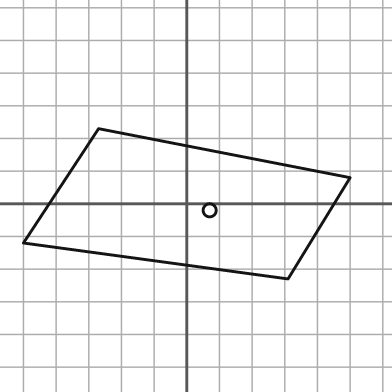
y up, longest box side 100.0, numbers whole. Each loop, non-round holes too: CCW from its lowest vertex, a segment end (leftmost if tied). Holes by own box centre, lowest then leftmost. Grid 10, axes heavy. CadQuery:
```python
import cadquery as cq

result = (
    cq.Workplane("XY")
    .moveTo(31.0, -23.0)
    .lineTo(50.0, 8.0)
    .lineTo(-27.0, 23.0)
    .lineTo(-50.0, -12.0)
    .close()
    .moveTo(7.0, -2.0)
    .circle(2.0)
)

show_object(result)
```